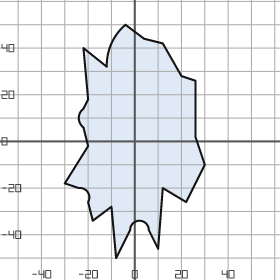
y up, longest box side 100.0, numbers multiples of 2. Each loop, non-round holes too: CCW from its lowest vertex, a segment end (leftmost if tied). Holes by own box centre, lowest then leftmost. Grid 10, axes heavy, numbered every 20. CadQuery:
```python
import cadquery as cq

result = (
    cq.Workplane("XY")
    .moveTo(-8.0, -50.0)
    .lineTo(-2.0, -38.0)
    .threePointArc((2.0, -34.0), (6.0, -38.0))
    .lineTo(10.0, -46.0)
    .lineTo(12.0, -20.0)
    .lineTo(22.0, -26.0)
    .lineTo(30.0, -10.0)
    .lineTo(26.0, 2.0)
    .lineTo(26.0, 26.0)
    .lineTo(20.0, 28.0)
    .lineTo(12.0, 42.0)
    .lineTo(4.0, 44.0)
    .lineTo(-4.0, 50.0)
    .threePointArc((-10.0, 42.0), (-12.0, 32.0))
    .lineTo(-22.0, 40.0)
    .lineTo(-20.0, 18.0)
    .lineTo(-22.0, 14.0)
    .threePointArc((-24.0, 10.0), (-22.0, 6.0))
    .lineTo(-20.0, -2.0)
    .lineTo(-30.0, -18.0)
    .lineTo(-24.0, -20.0)
    .threePointArc((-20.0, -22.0), (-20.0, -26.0))
    .lineTo(-18.0, -34.0)
    .lineTo(-10.0, -28.0)
    .close()
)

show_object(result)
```